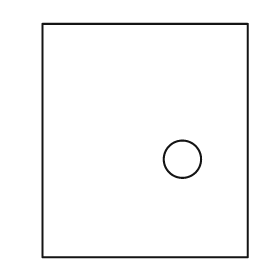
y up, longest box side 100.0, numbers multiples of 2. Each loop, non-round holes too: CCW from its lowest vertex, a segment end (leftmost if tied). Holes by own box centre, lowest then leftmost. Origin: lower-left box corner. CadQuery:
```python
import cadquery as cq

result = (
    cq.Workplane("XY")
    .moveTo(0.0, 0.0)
    .lineTo(88.0, 0.0)
    .lineTo(88.0, 100.0)
    .lineTo(0.0, 100.0)
    .close()
    .moveTo(60.0, 42.0)
    .circle(8.0)
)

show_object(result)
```